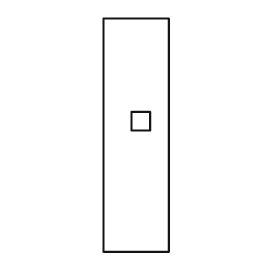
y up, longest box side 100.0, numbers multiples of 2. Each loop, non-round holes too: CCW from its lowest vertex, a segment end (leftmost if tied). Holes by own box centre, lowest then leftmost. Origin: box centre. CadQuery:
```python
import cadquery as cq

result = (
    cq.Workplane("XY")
    .moveTo(-14.0, -50.0)
    .lineTo(14.0, -50.0)
    .lineTo(14.0, 50.0)
    .lineTo(-14.0, 50.0)
    .close()
    .moveTo(-2.0, 2.0)
    .lineTo(6.0, 2.0)
    .lineTo(6.0, 10.0)
    .lineTo(-2.0, 10.0)
    .close()
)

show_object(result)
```